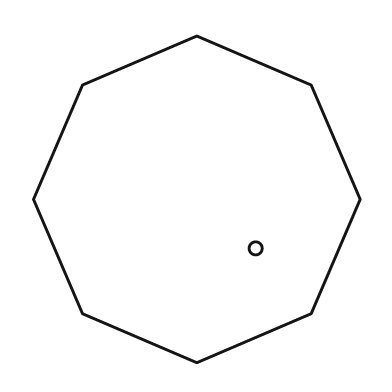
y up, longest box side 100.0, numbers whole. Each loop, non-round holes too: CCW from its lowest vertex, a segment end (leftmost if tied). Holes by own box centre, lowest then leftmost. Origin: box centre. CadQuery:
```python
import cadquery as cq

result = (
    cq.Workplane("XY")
    .moveTo(0.0, -50.0)
    .lineTo(35.0, -35.0)
    .lineTo(50.0, 0.0)
    .lineTo(35.0, 35.0)
    .lineTo(0.0, 50.0)
    .lineTo(-35.0, 35.0)
    .lineTo(-50.0, 0.0)
    .lineTo(-35.0, -35.0)
    .close()
    .moveTo(18.0, -15.0)
    .circle(2.0)
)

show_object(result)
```